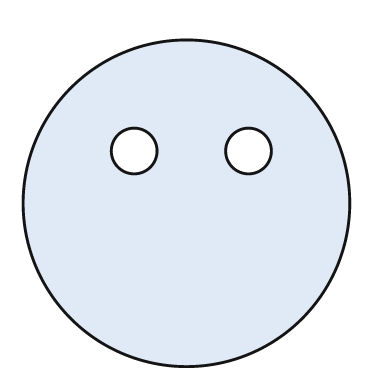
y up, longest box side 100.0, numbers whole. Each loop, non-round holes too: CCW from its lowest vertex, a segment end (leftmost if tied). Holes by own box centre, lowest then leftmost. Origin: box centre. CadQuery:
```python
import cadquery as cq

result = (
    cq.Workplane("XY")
    .moveTo(0.0, 0.0)
    .circle(50.0)
    .moveTo(-16.0, 16.0)
    .circle(7.0)
    .moveTo(19.0, 16.0)
    .circle(7.0)
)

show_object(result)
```